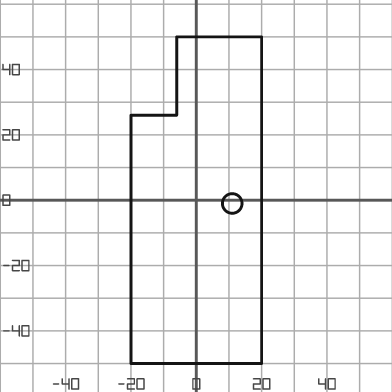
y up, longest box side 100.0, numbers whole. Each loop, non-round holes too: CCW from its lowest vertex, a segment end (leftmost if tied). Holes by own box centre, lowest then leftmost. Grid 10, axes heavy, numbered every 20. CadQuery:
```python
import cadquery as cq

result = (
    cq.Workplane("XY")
    .moveTo(-20.0, -50.0)
    .lineTo(20.0, -50.0)
    .lineTo(20.0, 50.0)
    .lineTo(-6.0, 50.0)
    .lineTo(-6.0, 26.0)
    .lineTo(-20.0, 26.0)
    .close()
    .moveTo(11.0, -1.0)
    .circle(3.0)
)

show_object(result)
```